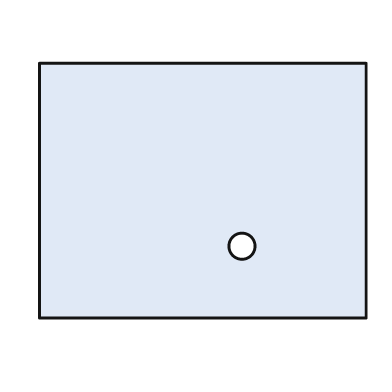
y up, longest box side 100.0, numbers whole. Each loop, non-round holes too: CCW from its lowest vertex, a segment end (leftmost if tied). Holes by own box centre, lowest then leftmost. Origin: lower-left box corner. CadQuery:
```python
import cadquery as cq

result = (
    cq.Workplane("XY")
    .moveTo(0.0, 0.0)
    .lineTo(100.0, 0.0)
    .lineTo(100.0, 78.0)
    .lineTo(0.0, 78.0)
    .close()
    .moveTo(62.0, 22.0)
    .circle(4.0)
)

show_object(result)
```